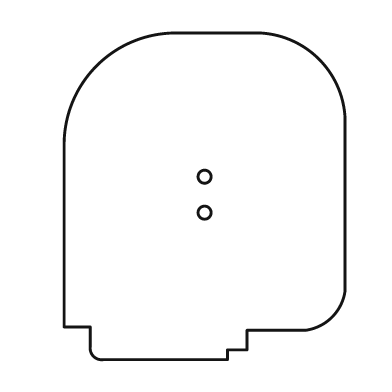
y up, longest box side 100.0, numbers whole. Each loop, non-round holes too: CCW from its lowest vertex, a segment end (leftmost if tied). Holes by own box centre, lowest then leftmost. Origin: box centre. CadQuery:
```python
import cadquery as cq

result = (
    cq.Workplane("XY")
    .moveTo(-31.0, -50.0)
    .lineTo(7.0, -50.0)
    .lineTo(7.0, -47.0)
    .lineTo(13.0, -47.0)
    .lineTo(13.0, -41.0)
    .lineTo(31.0, -41.0)
    .threePointArc((39.0, -37.0), (43.0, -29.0))
    .lineTo(43.0, 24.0)
    .threePointArc((35.0, 42.0), (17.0, 50.0))
    .lineTo(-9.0, 50.0)
    .threePointArc((-33.0, 40.0), (-43.0, 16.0))
    .lineTo(-43.0, -40.0)
    .lineTo(-35.0, -40.0)
    .lineTo(-35.0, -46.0)
    .threePointArc((-34.0, -49.0), (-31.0, -50.0))
    .close()
    .moveTo(0.0, -5.0)
    .circle(2.0)
    .moveTo(0.0, 6.0)
    .circle(2.0)
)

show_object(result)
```